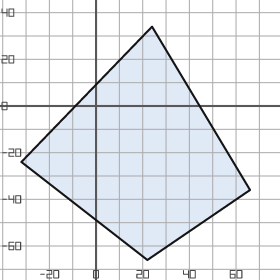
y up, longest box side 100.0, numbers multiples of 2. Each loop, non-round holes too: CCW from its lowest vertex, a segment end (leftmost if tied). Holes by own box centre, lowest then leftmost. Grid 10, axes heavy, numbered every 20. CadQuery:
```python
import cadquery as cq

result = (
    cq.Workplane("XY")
    .moveTo(22.0, -66.0)
    .lineTo(66.0, -36.0)
    .lineTo(24.0, 34.0)
    .lineTo(-32.0, -24.0)
    .close()
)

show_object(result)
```